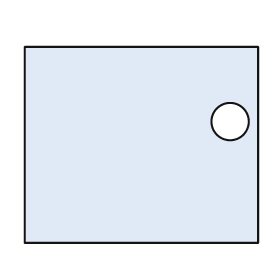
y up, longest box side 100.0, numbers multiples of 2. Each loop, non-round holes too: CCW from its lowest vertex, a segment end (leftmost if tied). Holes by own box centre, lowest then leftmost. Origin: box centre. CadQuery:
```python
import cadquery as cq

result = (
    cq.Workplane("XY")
    .moveTo(-50.0, -42.0)
    .lineTo(50.0, -42.0)
    .lineTo(50.0, 42.0)
    .lineTo(-50.0, 42.0)
    .close()
    .moveTo(38.0, 10.0)
    .circle(8.0)
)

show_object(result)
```